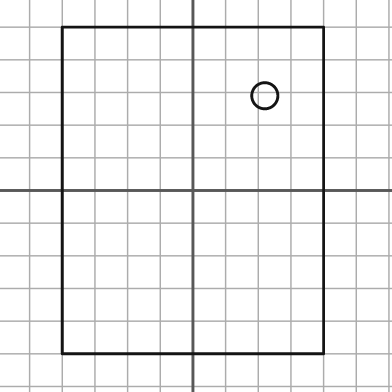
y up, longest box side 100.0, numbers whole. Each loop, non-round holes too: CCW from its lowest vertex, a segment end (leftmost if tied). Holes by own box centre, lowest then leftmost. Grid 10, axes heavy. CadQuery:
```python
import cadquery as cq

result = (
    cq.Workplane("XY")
    .moveTo(-40.0, -50.0)
    .lineTo(40.0, -50.0)
    .lineTo(40.0, 50.0)
    .lineTo(-40.0, 50.0)
    .close()
    .moveTo(22.0, 29.0)
    .circle(4.0)
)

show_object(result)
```